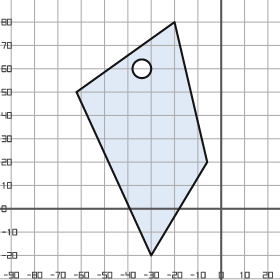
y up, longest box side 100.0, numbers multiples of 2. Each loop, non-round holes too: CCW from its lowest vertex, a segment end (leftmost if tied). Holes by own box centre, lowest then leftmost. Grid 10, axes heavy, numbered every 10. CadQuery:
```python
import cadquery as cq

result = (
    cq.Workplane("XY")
    .moveTo(-30.0, -20.0)
    .lineTo(-6.0, 20.0)
    .lineTo(-20.0, 80.0)
    .lineTo(-62.0, 50.0)
    .close()
    .moveTo(-34.0, 60.0)
    .circle(4.0)
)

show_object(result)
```